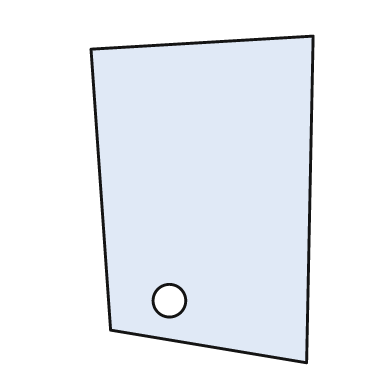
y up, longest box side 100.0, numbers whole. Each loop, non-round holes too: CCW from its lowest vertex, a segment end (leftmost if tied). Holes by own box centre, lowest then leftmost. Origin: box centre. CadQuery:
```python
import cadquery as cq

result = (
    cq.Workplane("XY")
    .moveTo(32.0, -50.0)
    .lineTo(34.0, 50.0)
    .lineTo(-34.0, 46.0)
    .lineTo(-28.0, -40.0)
    .close()
    .moveTo(-10.0, -31.0)
    .circle(5.0)
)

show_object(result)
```